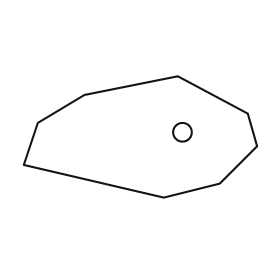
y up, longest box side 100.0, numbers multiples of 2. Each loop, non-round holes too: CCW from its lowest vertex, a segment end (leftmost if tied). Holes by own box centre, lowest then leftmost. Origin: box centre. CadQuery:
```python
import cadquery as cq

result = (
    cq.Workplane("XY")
    .moveTo(10.0, -26.0)
    .lineTo(34.0, -20.0)
    .lineTo(50.0, -4.0)
    .lineTo(46.0, 10.0)
    .lineTo(16.0, 26.0)
    .lineTo(-24.0, 18.0)
    .lineTo(-44.0, 6.0)
    .lineTo(-50.0, -12.0)
    .close()
    .moveTo(18.0, 2.0)
    .circle(4.0)
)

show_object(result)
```